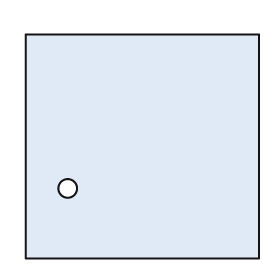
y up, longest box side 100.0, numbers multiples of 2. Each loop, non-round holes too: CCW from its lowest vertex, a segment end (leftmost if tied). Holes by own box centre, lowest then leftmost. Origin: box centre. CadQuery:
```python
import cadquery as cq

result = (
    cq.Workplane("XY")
    .moveTo(-50.0, -48.0)
    .lineTo(50.0, -48.0)
    .lineTo(50.0, 48.0)
    .lineTo(-50.0, 48.0)
    .close()
    .moveTo(-32.0, -18.0)
    .circle(4.0)
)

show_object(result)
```